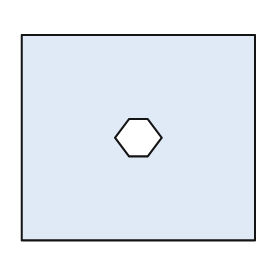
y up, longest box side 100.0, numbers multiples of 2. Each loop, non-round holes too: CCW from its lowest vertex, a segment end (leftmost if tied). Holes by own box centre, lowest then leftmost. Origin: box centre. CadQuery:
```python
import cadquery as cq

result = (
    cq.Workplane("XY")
    .moveTo(-50.0, -44.0)
    .lineTo(50.0, -44.0)
    .lineTo(50.0, 44.0)
    .lineTo(-50.0, 44.0)
    .close()
    .moveTo(-4.0, -8.0)
    .lineTo(4.0, -8.0)
    .lineTo(10.0, 0.0)
    .lineTo(4.0, 8.0)
    .lineTo(-4.0, 8.0)
    .lineTo(-10.0, 0.0)
    .close()
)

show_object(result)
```